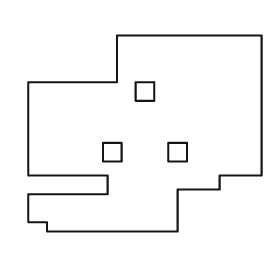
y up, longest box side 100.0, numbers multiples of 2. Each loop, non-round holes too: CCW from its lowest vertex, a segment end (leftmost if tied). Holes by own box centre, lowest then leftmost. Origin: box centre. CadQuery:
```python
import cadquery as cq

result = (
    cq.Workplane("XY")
    .moveTo(-42.0, -42.0)
    .lineTo(14.0, -42.0)
    .lineTo(14.0, -24.0)
    .lineTo(32.0, -24.0)
    .lineTo(32.0, -18.0)
    .lineTo(50.0, -18.0)
    .lineTo(50.0, 42.0)
    .lineTo(-12.0, 42.0)
    .lineTo(-12.0, 22.0)
    .lineTo(-50.0, 22.0)
    .lineTo(-50.0, -18.0)
    .lineTo(-16.0, -18.0)
    .lineTo(-16.0, -26.0)
    .lineTo(-50.0, -26.0)
    .lineTo(-50.0, -38.0)
    .lineTo(-42.0, -38.0)
    .close()
    .moveTo(-18.0, -12.0)
    .lineTo(-10.0, -12.0)
    .lineTo(-10.0, -4.0)
    .lineTo(-18.0, -4.0)
    .close()
    .moveTo(10.0, -12.0)
    .lineTo(18.0, -12.0)
    .lineTo(18.0, -4.0)
    .lineTo(10.0, -4.0)
    .close()
    .moveTo(-4.0, 14.0)
    .lineTo(4.0, 14.0)
    .lineTo(4.0, 22.0)
    .lineTo(-4.0, 22.0)
    .close()
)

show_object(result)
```